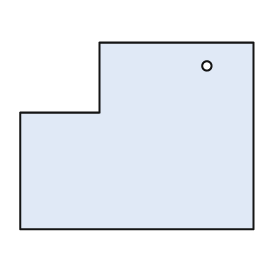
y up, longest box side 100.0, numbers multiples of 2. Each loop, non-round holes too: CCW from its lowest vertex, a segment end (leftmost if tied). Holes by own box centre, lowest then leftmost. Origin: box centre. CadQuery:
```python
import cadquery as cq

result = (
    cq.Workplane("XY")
    .moveTo(-50.0, -40.0)
    .lineTo(50.0, -40.0)
    .lineTo(50.0, 40.0)
    .lineTo(-16.0, 40.0)
    .lineTo(-16.0, 10.0)
    .lineTo(-50.0, 10.0)
    .close()
    .moveTo(30.0, 30.0)
    .circle(2.0)
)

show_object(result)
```